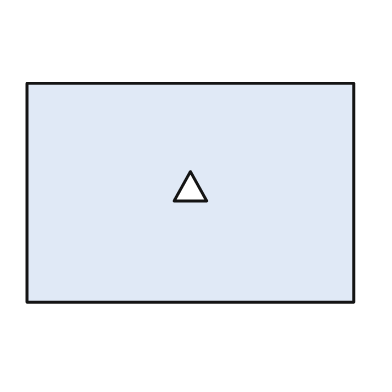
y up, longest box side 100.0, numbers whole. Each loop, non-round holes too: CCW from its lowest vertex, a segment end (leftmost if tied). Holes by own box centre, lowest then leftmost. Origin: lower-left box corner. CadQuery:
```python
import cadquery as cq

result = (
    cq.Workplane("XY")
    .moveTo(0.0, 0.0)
    .lineTo(100.0, 0.0)
    .lineTo(100.0, 67.0)
    .lineTo(0.0, 67.0)
    .close()
    .moveTo(45.0, 31.0)
    .lineTo(55.0, 31.0)
    .lineTo(50.0, 40.0)
    .close()
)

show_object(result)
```